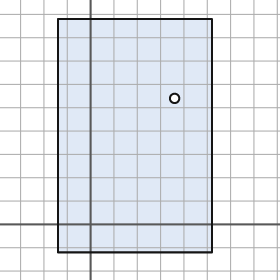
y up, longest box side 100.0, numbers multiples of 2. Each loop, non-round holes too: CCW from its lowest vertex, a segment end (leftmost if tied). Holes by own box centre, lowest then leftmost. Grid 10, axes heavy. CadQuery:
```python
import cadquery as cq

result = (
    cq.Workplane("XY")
    .moveTo(-14.0, -12.0)
    .lineTo(52.0, -12.0)
    .lineTo(52.0, 88.0)
    .lineTo(-14.0, 88.0)
    .close()
    .moveTo(36.0, 54.0)
    .circle(2.0)
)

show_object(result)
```